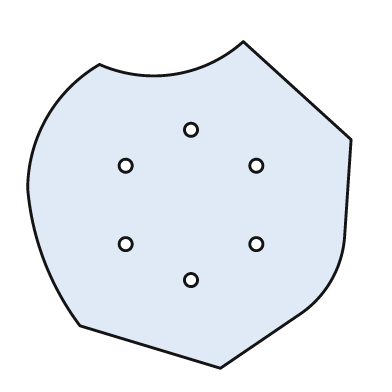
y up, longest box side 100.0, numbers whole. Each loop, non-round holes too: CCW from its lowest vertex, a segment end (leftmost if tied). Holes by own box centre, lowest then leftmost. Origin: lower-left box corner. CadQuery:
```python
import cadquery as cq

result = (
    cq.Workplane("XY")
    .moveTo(59.0, 0.0)
    .lineTo(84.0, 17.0)
    .threePointArc((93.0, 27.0), (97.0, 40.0))
    .lineTo(99.0, 70.0)
    .lineTo(66.0, 100.0)
    .threePointArc((45.0, 90.0), (22.0, 93.0))
    .threePointArc((6.0, 77.0), (0.0, 55.0))
    .threePointArc((5.0, 33.0), (16.0, 13.0))
    .close()
    .moveTo(50.0, 27.0)
    .circle(2.0)
    .moveTo(30.0, 38.0)
    .circle(2.0)
    .moveTo(70.0, 38.0)
    .circle(2.0)
    .moveTo(30.0, 62.0)
    .circle(2.0)
    .moveTo(70.0, 62.0)
    .circle(2.0)
    .moveTo(50.0, 73.0)
    .circle(2.0)
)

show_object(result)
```